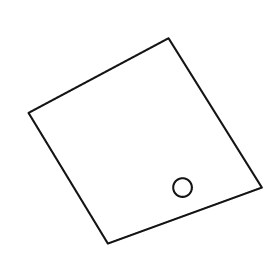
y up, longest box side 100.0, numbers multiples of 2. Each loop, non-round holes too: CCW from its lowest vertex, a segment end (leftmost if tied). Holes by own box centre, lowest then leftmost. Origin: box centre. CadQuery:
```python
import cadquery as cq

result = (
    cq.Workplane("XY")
    .moveTo(-16.0, -44.0)
    .lineTo(50.0, -20.0)
    .lineTo(10.0, 44.0)
    .lineTo(-50.0, 12.0)
    .close()
    .moveTo(16.0, -20.0)
    .circle(4.0)
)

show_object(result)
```